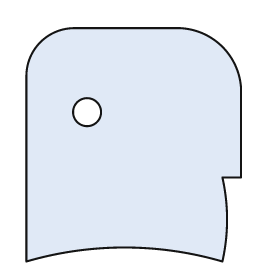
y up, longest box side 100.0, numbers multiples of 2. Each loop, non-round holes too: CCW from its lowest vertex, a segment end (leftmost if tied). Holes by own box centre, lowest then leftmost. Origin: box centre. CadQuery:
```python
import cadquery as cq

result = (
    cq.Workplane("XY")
    .moveTo(-46.0, -50.0)
    .threePointArc((-4.0, -44.0), (38.0, -50.0))
    .threePointArc((40.0, -32.0), (38.0, -14.0))
    .lineTo(46.0, -14.0)
    .lineTo(46.0, 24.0)
    .threePointArc((38.0, 42.0), (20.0, 50.0))
    .lineTo(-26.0, 50.0)
    .threePointArc((-40.0, 44.0), (-46.0, 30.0))
    .close()
    .moveTo(-20.0, 14.0)
    .circle(6.0)
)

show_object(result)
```